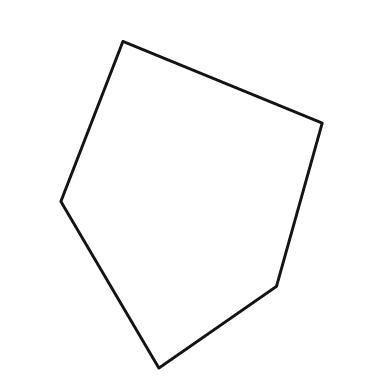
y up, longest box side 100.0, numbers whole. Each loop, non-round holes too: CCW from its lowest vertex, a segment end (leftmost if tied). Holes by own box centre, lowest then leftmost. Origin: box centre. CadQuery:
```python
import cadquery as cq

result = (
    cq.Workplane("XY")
    .moveTo(-10.0, -50.0)
    .lineTo(26.0, -25.0)
    .lineTo(40.0, 25.0)
    .lineTo(-21.0, 50.0)
    .lineTo(-40.0, 1.0)
    .close()
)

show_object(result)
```